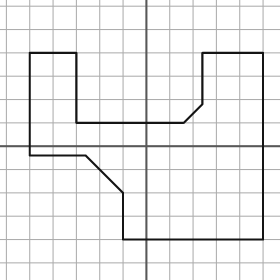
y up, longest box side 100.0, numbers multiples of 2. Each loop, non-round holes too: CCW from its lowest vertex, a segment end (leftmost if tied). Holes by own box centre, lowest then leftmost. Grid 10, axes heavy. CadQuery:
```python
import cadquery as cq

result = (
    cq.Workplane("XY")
    .moveTo(-10.0, -40.0)
    .lineTo(50.0, -40.0)
    .lineTo(50.0, 40.0)
    .lineTo(24.0, 40.0)
    .lineTo(24.0, 18.0)
    .lineTo(16.0, 10.0)
    .lineTo(-30.0, 10.0)
    .lineTo(-30.0, 40.0)
    .lineTo(-50.0, 40.0)
    .lineTo(-50.0, -4.0)
    .lineTo(-26.0, -4.0)
    .lineTo(-10.0, -20.0)
    .close()
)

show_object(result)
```